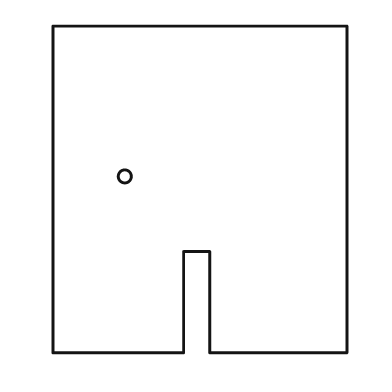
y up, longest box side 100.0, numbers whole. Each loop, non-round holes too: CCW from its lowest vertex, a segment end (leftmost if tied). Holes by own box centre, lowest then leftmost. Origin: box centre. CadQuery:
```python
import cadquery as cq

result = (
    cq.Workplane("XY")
    .moveTo(-45.0, -50.0)
    .lineTo(-5.0, -50.0)
    .lineTo(-5.0, -19.0)
    .lineTo(3.0, -19.0)
    .lineTo(3.0, -50.0)
    .lineTo(45.0, -50.0)
    .lineTo(45.0, 50.0)
    .lineTo(-45.0, 50.0)
    .close()
    .moveTo(-23.0, 4.0)
    .circle(2.0)
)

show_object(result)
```